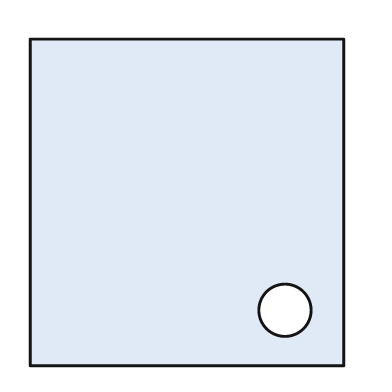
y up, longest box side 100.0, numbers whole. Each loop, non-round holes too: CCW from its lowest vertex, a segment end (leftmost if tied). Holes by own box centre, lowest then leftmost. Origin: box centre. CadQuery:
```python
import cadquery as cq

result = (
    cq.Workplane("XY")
    .moveTo(-48.0, -50.0)
    .lineTo(48.0, -50.0)
    .lineTo(48.0, 50.0)
    .lineTo(-48.0, 50.0)
    .close()
    .moveTo(30.0, -33.0)
    .circle(8.0)
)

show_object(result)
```